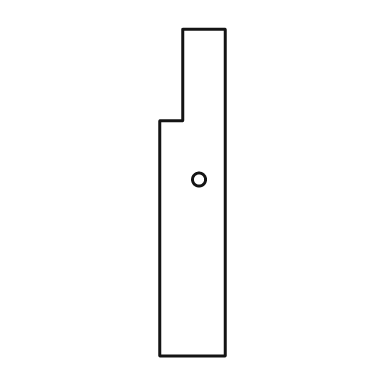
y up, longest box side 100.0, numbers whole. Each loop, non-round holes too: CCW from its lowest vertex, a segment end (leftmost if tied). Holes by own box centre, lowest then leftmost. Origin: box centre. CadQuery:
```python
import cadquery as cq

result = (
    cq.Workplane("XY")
    .moveTo(-10.0, -50.0)
    .lineTo(10.0, -50.0)
    .lineTo(10.0, 50.0)
    .lineTo(-3.0, 50.0)
    .lineTo(-3.0, 22.0)
    .lineTo(-10.0, 22.0)
    .close()
    .moveTo(2.0, 4.0)
    .circle(2.0)
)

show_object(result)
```